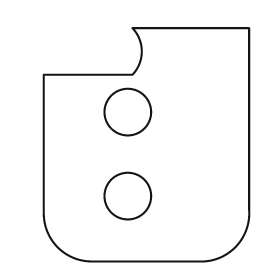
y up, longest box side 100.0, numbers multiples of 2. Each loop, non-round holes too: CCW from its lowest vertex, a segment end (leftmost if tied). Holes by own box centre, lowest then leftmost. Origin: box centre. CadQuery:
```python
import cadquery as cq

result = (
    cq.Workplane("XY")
    .moveTo(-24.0, -50.0)
    .lineTo(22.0, -50.0)
    .threePointArc((38.0, -44.0), (44.0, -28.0))
    .lineTo(44.0, 50.0)
    .lineTo(-6.0, 50.0)
    .threePointArc((-2.0, 40.0), (-6.0, 30.0))
    .lineTo(-44.0, 30.0)
    .lineTo(-44.0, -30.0)
    .threePointArc((-38.0, -44.0), (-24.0, -50.0))
    .close()
    .moveTo(-8.0, -22.0)
    .circle(10.0)
    .moveTo(-8.0, 14.0)
    .circle(10.0)
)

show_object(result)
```